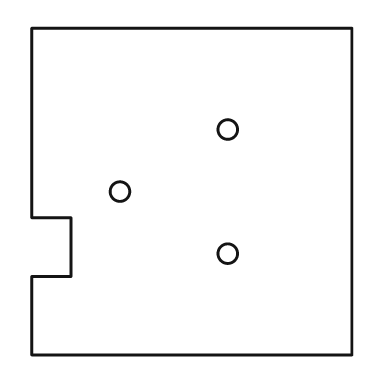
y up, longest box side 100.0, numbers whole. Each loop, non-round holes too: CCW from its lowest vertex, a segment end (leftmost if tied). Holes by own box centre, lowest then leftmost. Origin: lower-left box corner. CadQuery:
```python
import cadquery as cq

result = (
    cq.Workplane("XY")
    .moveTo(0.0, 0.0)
    .lineTo(98.0, 0.0)
    .lineTo(98.0, 100.0)
    .lineTo(0.0, 100.0)
    .lineTo(0.0, 42.0)
    .lineTo(12.0, 42.0)
    .lineTo(12.0, 24.0)
    .lineTo(0.0, 24.0)
    .close()
    .moveTo(60.0, 31.0)
    .circle(3.0)
    .moveTo(27.0, 50.0)
    .circle(3.0)
    .moveTo(60.0, 69.0)
    .circle(3.0)
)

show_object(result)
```